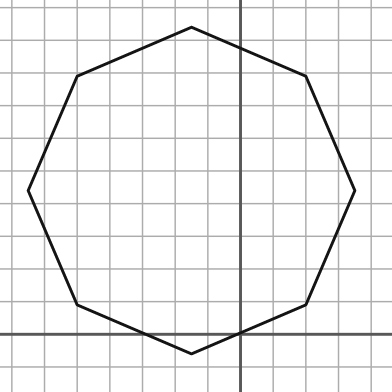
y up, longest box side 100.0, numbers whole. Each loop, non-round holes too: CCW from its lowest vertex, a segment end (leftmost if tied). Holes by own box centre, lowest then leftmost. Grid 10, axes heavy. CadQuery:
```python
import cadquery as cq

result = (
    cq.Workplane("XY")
    .moveTo(-15.0, -6.0)
    .lineTo(20.0, 9.0)
    .lineTo(35.0, 44.0)
    .lineTo(20.0, 79.0)
    .lineTo(-15.0, 94.0)
    .lineTo(-50.0, 79.0)
    .lineTo(-65.0, 44.0)
    .lineTo(-50.0, 9.0)
    .close()
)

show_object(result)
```